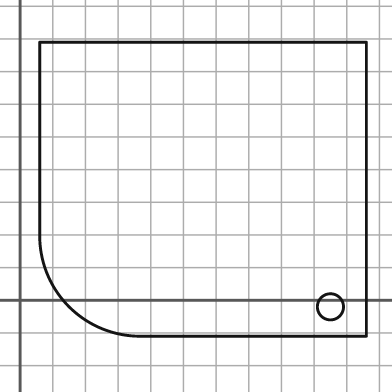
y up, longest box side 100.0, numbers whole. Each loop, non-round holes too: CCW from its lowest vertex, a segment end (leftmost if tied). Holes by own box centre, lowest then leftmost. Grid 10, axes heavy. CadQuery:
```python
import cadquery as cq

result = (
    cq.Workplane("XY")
    .moveTo(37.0, -11.0)
    .lineTo(106.0, -11.0)
    .lineTo(106.0, 79.0)
    .lineTo(6.0, 79.0)
    .lineTo(6.0, 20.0)
    .threePointArc((15.0, -2.0), (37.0, -11.0))
    .close()
    .moveTo(95.0, -2.0)
    .circle(4.0)
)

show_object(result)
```